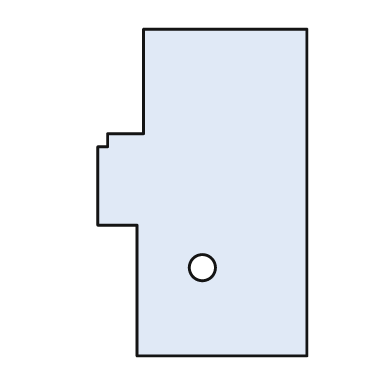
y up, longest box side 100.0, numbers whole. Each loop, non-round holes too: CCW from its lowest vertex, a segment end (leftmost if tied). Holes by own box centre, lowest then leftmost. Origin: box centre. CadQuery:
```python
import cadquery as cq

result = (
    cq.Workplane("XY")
    .moveTo(-20.0, -50.0)
    .lineTo(32.0, -50.0)
    .lineTo(32.0, 50.0)
    .lineTo(-18.0, 50.0)
    .lineTo(-18.0, 18.0)
    .lineTo(-29.0, 18.0)
    .lineTo(-29.0, 14.0)
    .lineTo(-32.0, 14.0)
    .lineTo(-32.0, -10.0)
    .lineTo(-20.0, -10.0)
    .close()
    .moveTo(0.0, -23.0)
    .circle(4.0)
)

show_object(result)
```